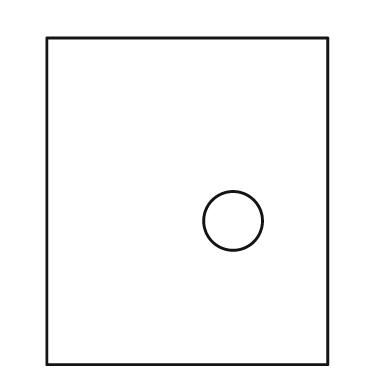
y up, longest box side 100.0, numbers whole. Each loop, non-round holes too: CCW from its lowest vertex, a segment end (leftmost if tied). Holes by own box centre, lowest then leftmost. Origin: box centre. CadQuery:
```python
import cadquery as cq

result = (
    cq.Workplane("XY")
    .moveTo(-43.0, -50.0)
    .lineTo(43.0, -50.0)
    .lineTo(43.0, 50.0)
    .lineTo(-43.0, 50.0)
    .close()
    .moveTo(14.0, -6.0)
    .circle(9.0)
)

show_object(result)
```